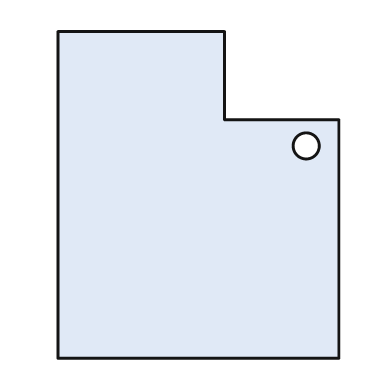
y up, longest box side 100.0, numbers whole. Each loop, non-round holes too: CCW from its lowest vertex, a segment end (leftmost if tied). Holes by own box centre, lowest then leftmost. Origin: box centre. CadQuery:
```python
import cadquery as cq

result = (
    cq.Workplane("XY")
    .moveTo(-43.0, -50.0)
    .lineTo(43.0, -50.0)
    .lineTo(43.0, 23.0)
    .lineTo(8.0, 23.0)
    .lineTo(8.0, 50.0)
    .lineTo(-43.0, 50.0)
    .close()
    .moveTo(33.0, 15.0)
    .circle(4.0)
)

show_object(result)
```